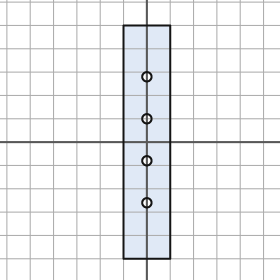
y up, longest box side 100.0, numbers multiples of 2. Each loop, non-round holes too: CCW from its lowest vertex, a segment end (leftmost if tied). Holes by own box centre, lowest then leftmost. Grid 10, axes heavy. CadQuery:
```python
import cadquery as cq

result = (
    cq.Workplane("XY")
    .moveTo(-10.0, -50.0)
    .lineTo(10.0, -50.0)
    .lineTo(10.0, 50.0)
    .lineTo(-10.0, 50.0)
    .close()
    .moveTo(0.0, -26.0)
    .circle(2.0)
    .moveTo(0.0, -8.0)
    .circle(2.0)
    .moveTo(0.0, 10.0)
    .circle(2.0)
    .moveTo(0.0, 28.0)
    .circle(2.0)
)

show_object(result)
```